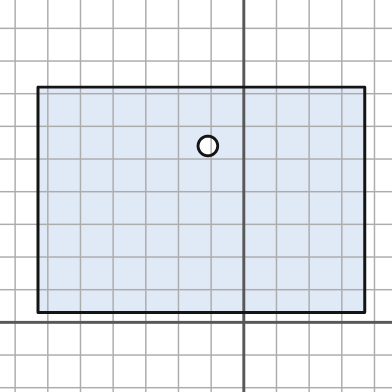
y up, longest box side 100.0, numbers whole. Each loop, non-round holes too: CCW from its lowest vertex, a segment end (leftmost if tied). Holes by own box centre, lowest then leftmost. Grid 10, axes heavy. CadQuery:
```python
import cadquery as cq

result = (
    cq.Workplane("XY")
    .moveTo(-63.0, 3.0)
    .lineTo(37.0, 3.0)
    .lineTo(37.0, 72.0)
    .lineTo(-63.0, 72.0)
    .close()
    .moveTo(-11.0, 54.0)
    .circle(3.0)
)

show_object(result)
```